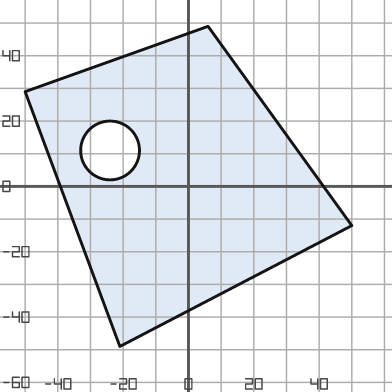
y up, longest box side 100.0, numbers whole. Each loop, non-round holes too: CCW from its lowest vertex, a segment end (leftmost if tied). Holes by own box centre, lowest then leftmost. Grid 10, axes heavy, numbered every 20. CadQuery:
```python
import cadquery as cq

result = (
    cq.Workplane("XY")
    .moveTo(-21.0, -49.0)
    .lineTo(50.0, -12.0)
    .lineTo(6.0, 49.0)
    .lineTo(-50.0, 29.0)
    .close()
    .moveTo(-24.0, 11.0)
    .circle(9.0)
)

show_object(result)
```